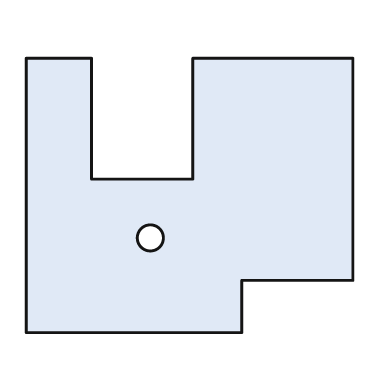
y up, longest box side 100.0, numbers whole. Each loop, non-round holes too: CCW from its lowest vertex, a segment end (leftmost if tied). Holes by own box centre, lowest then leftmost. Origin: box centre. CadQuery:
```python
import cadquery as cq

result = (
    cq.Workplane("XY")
    .moveTo(-50.0, -42.0)
    .lineTo(16.0, -42.0)
    .lineTo(16.0, -26.0)
    .lineTo(50.0, -26.0)
    .lineTo(50.0, 42.0)
    .lineTo(1.0, 42.0)
    .lineTo(1.0, 5.0)
    .lineTo(-30.0, 5.0)
    .lineTo(-30.0, 42.0)
    .lineTo(-50.0, 42.0)
    .close()
    .moveTo(-12.0, -13.0)
    .circle(4.0)
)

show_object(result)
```